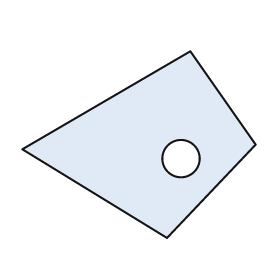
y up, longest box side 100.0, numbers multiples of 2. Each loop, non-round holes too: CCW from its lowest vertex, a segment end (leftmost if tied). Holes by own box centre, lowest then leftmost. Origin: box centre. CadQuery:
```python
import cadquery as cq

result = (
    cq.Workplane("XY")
    .moveTo(12.0, -40.0)
    .lineTo(50.0, 0.0)
    .lineTo(22.0, 40.0)
    .lineTo(-50.0, -2.0)
    .close()
    .moveTo(18.0, -6.0)
    .circle(8.0)
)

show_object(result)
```